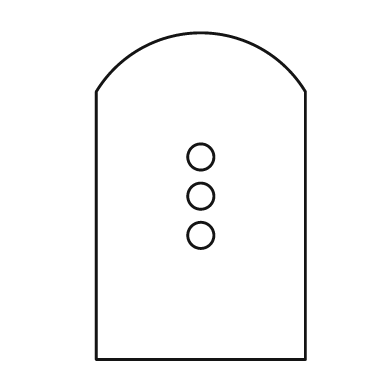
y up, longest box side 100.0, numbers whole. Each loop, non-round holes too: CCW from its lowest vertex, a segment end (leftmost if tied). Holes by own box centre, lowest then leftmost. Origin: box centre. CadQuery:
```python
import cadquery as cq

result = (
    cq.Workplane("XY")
    .moveTo(-32.0, -50.0)
    .lineTo(32.0, -50.0)
    .lineTo(32.0, 32.0)
    .threePointArc((0.0, 50.0), (-32.0, 32.0))
    .close()
    .moveTo(0.0, -12.0)
    .circle(4.0)
    .moveTo(0.0, 0.0)
    .circle(4.0)
    .moveTo(0.0, 12.0)
    .circle(4.0)
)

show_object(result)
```